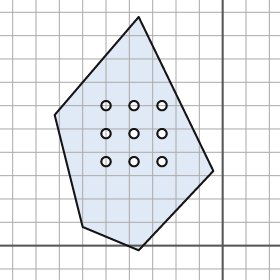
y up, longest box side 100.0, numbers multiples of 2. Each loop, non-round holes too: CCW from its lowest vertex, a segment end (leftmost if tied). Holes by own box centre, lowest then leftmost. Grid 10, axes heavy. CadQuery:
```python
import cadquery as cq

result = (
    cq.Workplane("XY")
    .moveTo(-36.0, -2.0)
    .lineTo(-4.0, 32.0)
    .lineTo(-36.0, 98.0)
    .lineTo(-72.0, 56.0)
    .lineTo(-60.0, 8.0)
    .close()
    .moveTo(-50.0, 36.0)
    .circle(2.0)
    .moveTo(-38.0, 36.0)
    .circle(2.0)
    .moveTo(-26.0, 36.0)
    .circle(2.0)
    .moveTo(-50.0, 48.0)
    .circle(2.0)
    .moveTo(-38.0, 48.0)
    .circle(2.0)
    .moveTo(-26.0, 48.0)
    .circle(2.0)
    .moveTo(-50.0, 60.0)
    .circle(2.0)
    .moveTo(-38.0, 60.0)
    .circle(2.0)
    .moveTo(-26.0, 60.0)
    .circle(2.0)
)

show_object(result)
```